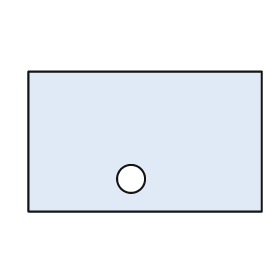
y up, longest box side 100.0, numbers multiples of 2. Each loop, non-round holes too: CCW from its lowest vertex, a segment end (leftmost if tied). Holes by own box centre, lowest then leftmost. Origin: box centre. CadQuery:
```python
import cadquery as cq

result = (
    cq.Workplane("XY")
    .moveTo(-50.0, -30.0)
    .lineTo(50.0, -30.0)
    .lineTo(50.0, 30.0)
    .lineTo(-50.0, 30.0)
    .close()
    .moveTo(-6.0, -16.0)
    .circle(6.0)
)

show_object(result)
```